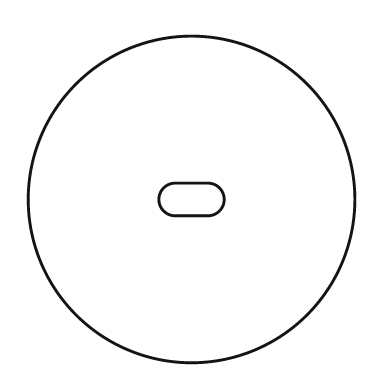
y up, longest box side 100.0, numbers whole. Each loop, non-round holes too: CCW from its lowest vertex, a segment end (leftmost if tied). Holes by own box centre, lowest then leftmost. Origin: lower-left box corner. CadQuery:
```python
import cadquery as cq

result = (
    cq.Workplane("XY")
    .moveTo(50.0, 50.0)
    .circle(50.0)
    .moveTo(45.0, 45.0)
    .lineTo(55.0, 45.0)
    .threePointArc((60.0, 50.0), (55.0, 55.0))
    .lineTo(45.0, 55.0)
    .threePointArc((40.0, 50.0), (45.0, 45.0))
    .close()
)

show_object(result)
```